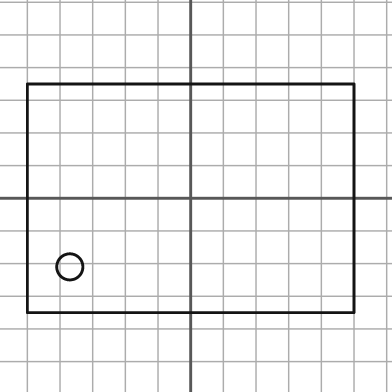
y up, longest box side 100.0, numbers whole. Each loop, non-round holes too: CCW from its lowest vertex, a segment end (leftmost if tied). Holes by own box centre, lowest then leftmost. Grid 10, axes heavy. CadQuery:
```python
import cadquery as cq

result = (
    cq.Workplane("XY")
    .moveTo(-50.0, -35.0)
    .lineTo(50.0, -35.0)
    .lineTo(50.0, 35.0)
    .lineTo(-50.0, 35.0)
    .close()
    .moveTo(-37.0, -21.0)
    .circle(4.0)
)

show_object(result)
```